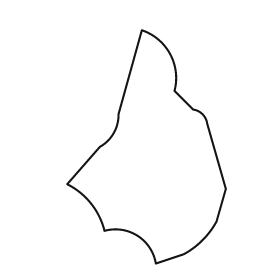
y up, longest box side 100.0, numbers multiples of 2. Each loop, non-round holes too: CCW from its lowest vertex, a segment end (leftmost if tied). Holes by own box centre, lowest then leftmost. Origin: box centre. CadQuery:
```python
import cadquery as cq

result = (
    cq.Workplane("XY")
    .moveTo(4.0, -50.0)
    .lineTo(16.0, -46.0)
    .threePointArc((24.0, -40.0), (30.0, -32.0))
    .lineTo(34.0, -18.0)
    .lineTo(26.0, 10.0)
    .threePointArc((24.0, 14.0), (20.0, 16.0))
    .lineTo(12.0, 24.0)
    .threePointArc((10.0, 40.0), (-2.0, 50.0))
    .lineTo(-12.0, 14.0)
    .threePointArc((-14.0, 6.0), (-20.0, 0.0))
    .lineTo(-34.0, -16.0)
    .threePointArc((-24.0, -24.0), (-18.0, -36.0))
    .threePointArc((-4.0, -38.0), (4.0, -50.0))
    .close()
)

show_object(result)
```